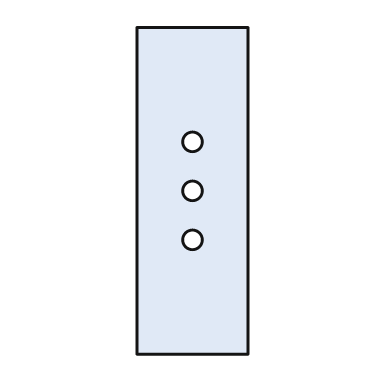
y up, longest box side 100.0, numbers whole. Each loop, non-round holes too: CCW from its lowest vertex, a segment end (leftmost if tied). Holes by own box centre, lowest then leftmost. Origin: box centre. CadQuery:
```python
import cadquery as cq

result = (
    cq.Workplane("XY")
    .moveTo(-17.0, -50.0)
    .lineTo(17.0, -50.0)
    .lineTo(17.0, 50.0)
    .lineTo(-17.0, 50.0)
    .close()
    .moveTo(0.0, -15.0)
    .circle(3.0)
    .moveTo(0.0, 0.0)
    .circle(3.0)
    .moveTo(0.0, 15.0)
    .circle(3.0)
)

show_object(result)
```